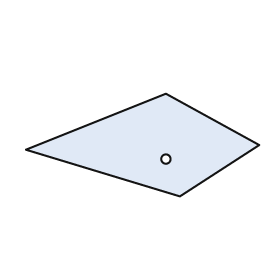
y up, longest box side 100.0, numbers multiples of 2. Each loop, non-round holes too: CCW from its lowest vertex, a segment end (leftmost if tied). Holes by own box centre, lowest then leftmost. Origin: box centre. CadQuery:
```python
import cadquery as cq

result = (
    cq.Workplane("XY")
    .moveTo(16.0, -22.0)
    .lineTo(50.0, 0.0)
    .lineTo(10.0, 22.0)
    .lineTo(-50.0, -2.0)
    .close()
    .moveTo(10.0, -6.0)
    .circle(2.0)
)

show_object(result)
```